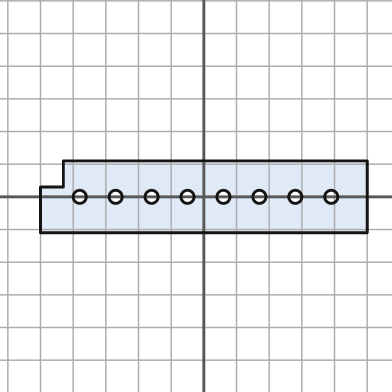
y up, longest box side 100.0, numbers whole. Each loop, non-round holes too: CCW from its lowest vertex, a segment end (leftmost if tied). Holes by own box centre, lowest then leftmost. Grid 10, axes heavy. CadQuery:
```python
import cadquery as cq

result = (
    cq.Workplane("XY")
    .moveTo(-50.0, -11.0)
    .lineTo(50.0, -11.0)
    .lineTo(50.0, 11.0)
    .lineTo(-43.0, 11.0)
    .lineTo(-43.0, 3.0)
    .lineTo(-50.0, 3.0)
    .close()
    .moveTo(-38.0, 0.0)
    .circle(2.0)
    .moveTo(-27.0, 0.0)
    .circle(2.0)
    .moveTo(-16.0, 0.0)
    .circle(2.0)
    .moveTo(-5.0, 0.0)
    .circle(2.0)
    .moveTo(6.0, 0.0)
    .circle(2.0)
    .moveTo(17.0, 0.0)
    .circle(2.0)
    .moveTo(28.0, 0.0)
    .circle(2.0)
    .moveTo(39.0, 0.0)
    .circle(2.0)
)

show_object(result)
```